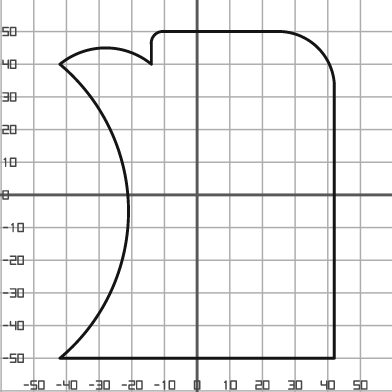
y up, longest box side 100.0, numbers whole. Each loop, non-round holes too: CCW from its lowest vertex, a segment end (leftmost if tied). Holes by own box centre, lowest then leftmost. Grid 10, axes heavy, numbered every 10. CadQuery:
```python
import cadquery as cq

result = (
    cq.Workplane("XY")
    .moveTo(-42.0, -50.0)
    .lineTo(42.0, -50.0)
    .lineTo(42.0, 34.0)
    .threePointArc((37.0, 45.0), (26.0, 50.0))
    .lineTo(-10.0, 50.0)
    .threePointArc((-13.0, 49.0), (-14.0, 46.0))
    .lineTo(-14.0, 40.0)
    .threePointArc((-28.0, 45.0), (-42.0, 40.0))
    .threePointArc((-21.0, -5.0), (-42.0, -50.0))
    .close()
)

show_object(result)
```